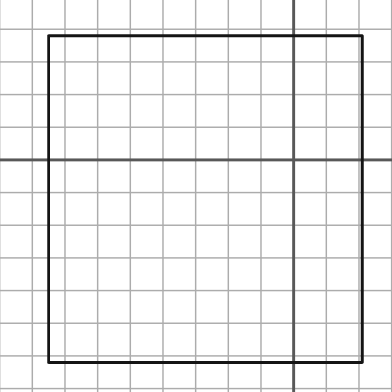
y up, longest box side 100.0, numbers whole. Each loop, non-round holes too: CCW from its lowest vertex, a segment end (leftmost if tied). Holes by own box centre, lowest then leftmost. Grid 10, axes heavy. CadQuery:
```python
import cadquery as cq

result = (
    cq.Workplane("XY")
    .moveTo(-75.0, -62.0)
    .lineTo(21.0, -62.0)
    .lineTo(21.0, 38.0)
    .lineTo(-75.0, 38.0)
    .close()
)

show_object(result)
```